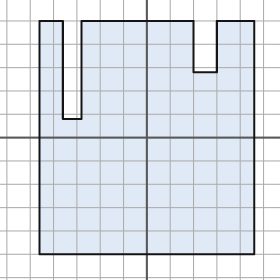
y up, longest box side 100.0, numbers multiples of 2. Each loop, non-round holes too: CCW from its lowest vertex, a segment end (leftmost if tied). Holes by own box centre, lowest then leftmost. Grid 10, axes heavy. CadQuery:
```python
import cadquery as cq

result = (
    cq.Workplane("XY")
    .moveTo(-46.0, -50.0)
    .lineTo(46.0, -50.0)
    .lineTo(46.0, 50.0)
    .lineTo(30.0, 50.0)
    .lineTo(30.0, 28.0)
    .lineTo(20.0, 28.0)
    .lineTo(20.0, 50.0)
    .lineTo(-28.0, 50.0)
    .lineTo(-28.0, 8.0)
    .lineTo(-36.0, 8.0)
    .lineTo(-36.0, 50.0)
    .lineTo(-46.0, 50.0)
    .close()
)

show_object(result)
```